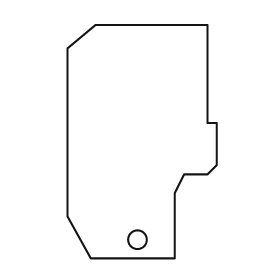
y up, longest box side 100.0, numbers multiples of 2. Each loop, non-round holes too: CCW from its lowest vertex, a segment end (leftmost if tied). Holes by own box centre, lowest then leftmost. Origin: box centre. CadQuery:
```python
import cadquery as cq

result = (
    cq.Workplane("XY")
    .moveTo(-22.0, -50.0)
    .lineTo(14.0, -50.0)
    .lineTo(14.0, -22.0)
    .lineTo(18.0, -14.0)
    .lineTo(28.0, -14.0)
    .lineTo(32.0, -10.0)
    .lineTo(32.0, 8.0)
    .lineTo(28.0, 8.0)
    .lineTo(28.0, 50.0)
    .lineTo(-20.0, 50.0)
    .lineTo(-32.0, 40.0)
    .lineTo(-32.0, -32.0)
    .close()
    .moveTo(-2.0, -42.0)
    .circle(4.0)
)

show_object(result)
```